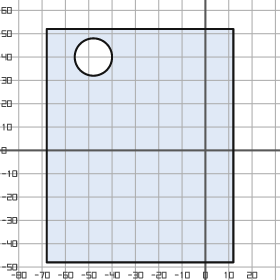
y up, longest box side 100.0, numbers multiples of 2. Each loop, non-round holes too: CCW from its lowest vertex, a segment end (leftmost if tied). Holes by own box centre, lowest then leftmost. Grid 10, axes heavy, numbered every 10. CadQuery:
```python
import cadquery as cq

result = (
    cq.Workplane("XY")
    .moveTo(-68.0, -48.0)
    .lineTo(12.0, -48.0)
    .lineTo(12.0, 52.0)
    .lineTo(-68.0, 52.0)
    .close()
    .moveTo(-48.0, 40.0)
    .circle(8.0)
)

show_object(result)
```